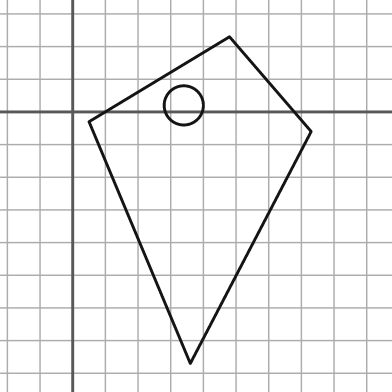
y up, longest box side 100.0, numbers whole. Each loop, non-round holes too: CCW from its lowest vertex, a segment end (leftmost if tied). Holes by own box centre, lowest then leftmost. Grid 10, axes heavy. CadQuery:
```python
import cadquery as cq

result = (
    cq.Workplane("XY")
    .moveTo(36.0, -77.0)
    .lineTo(73.0, -6.0)
    .lineTo(48.0, 23.0)
    .lineTo(5.0, -3.0)
    .close()
    .moveTo(34.0, 2.0)
    .circle(6.0)
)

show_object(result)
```